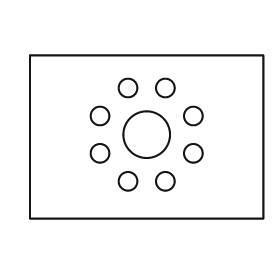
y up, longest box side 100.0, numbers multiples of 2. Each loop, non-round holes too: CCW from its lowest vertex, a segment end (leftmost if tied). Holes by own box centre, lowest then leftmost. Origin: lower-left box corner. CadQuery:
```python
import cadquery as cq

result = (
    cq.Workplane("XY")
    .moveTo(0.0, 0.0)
    .lineTo(100.0, 0.0)
    .lineTo(100.0, 70.0)
    .lineTo(0.0, 70.0)
    .close()
    .moveTo(42.0, 16.0)
    .circle(4.0)
    .moveTo(58.0, 16.0)
    .circle(4.0)
    .moveTo(30.0, 28.0)
    .circle(4.0)
    .moveTo(70.0, 28.0)
    .circle(4.0)
    .moveTo(50.0, 36.0)
    .circle(10.0)
    .moveTo(30.0, 44.0)
    .circle(4.0)
    .moveTo(70.0, 44.0)
    .circle(4.0)
    .moveTo(42.0, 56.0)
    .circle(4.0)
    .moveTo(58.0, 56.0)
    .circle(4.0)
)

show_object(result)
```